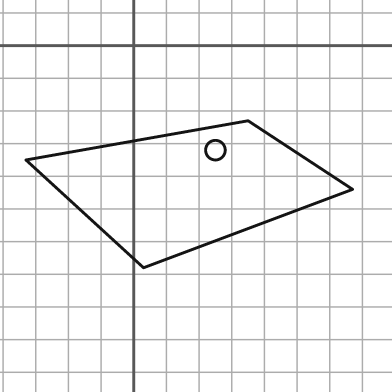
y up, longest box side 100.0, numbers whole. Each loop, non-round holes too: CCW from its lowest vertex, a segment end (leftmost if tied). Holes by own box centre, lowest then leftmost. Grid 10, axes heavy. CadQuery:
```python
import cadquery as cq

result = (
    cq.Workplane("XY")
    .moveTo(3.0, -68.0)
    .lineTo(67.0, -44.0)
    .lineTo(35.0, -23.0)
    .lineTo(-33.0, -35.0)
    .close()
    .moveTo(25.0, -32.0)
    .circle(3.0)
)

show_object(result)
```